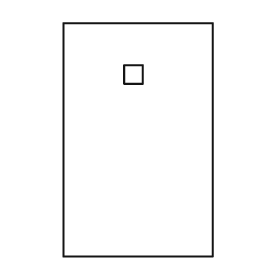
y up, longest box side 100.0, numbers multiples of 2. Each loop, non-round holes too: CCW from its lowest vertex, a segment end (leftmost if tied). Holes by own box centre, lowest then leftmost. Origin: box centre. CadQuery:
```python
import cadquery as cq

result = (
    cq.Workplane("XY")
    .moveTo(-32.0, -50.0)
    .lineTo(32.0, -50.0)
    .lineTo(32.0, 50.0)
    .lineTo(-32.0, 50.0)
    .close()
    .moveTo(-6.0, 24.0)
    .lineTo(2.0, 24.0)
    .lineTo(2.0, 32.0)
    .lineTo(-6.0, 32.0)
    .close()
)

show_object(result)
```